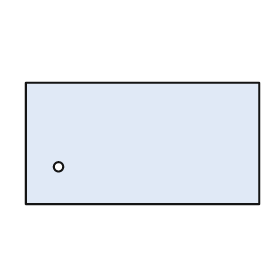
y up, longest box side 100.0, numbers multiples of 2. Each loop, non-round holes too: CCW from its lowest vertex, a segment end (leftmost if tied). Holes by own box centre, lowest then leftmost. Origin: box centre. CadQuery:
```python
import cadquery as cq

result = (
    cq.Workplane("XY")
    .moveTo(-50.0, -26.0)
    .lineTo(50.0, -26.0)
    .lineTo(50.0, 26.0)
    .lineTo(-50.0, 26.0)
    .close()
    .moveTo(-36.0, -10.0)
    .circle(2.0)
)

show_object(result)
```